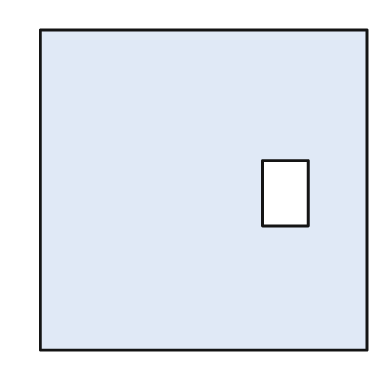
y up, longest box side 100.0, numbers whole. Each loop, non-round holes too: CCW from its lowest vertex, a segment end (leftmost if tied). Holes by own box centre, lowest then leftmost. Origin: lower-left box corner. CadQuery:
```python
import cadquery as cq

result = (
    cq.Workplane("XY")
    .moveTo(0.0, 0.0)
    .lineTo(100.0, 0.0)
    .lineTo(100.0, 98.0)
    .lineTo(0.0, 98.0)
    .close()
    .moveTo(68.0, 38.0)
    .lineTo(82.0, 38.0)
    .lineTo(82.0, 58.0)
    .lineTo(68.0, 58.0)
    .close()
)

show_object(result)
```